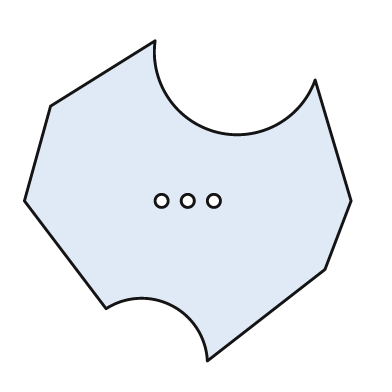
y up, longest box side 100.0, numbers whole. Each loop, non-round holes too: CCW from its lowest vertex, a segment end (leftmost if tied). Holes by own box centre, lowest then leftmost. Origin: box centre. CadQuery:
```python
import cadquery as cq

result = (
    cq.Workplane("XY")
    .moveTo(6.0, -49.0)
    .lineTo(42.0, -21.0)
    .lineTo(50.0, 0.0)
    .lineTo(39.0, 37.0)
    .threePointArc((9.0, 21.0), (-10.0, 49.0))
    .lineTo(-42.0, 29.0)
    .lineTo(-50.0, 0.0)
    .lineTo(-25.0, -33.0)
    .threePointArc((-5.0, -32.0), (6.0, -49.0))
    .close()
    .moveTo(-8.0, 0.0)
    .circle(2.0)
    .moveTo(0.0, 0.0)
    .circle(2.0)
    .moveTo(8.0, 0.0)
    .circle(2.0)
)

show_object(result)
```